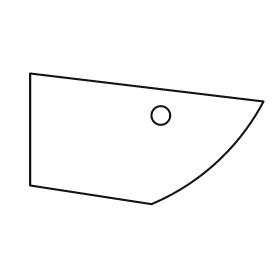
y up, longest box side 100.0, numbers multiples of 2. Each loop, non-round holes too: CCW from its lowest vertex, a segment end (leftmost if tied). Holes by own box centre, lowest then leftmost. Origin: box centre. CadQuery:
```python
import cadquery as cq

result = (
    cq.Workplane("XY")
    .moveTo(2.0, -28.0)
    .threePointArc((30.0, -10.0), (50.0, 16.0))
    .lineTo(-50.0, 28.0)
    .lineTo(-50.0, -20.0)
    .close()
    .moveTo(6.0, 10.0)
    .circle(4.0)
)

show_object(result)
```